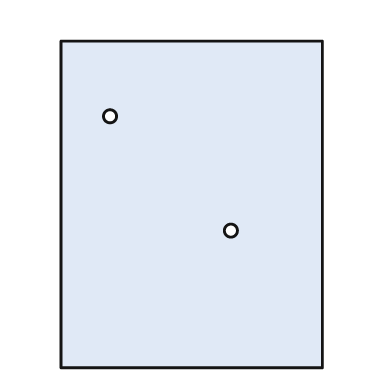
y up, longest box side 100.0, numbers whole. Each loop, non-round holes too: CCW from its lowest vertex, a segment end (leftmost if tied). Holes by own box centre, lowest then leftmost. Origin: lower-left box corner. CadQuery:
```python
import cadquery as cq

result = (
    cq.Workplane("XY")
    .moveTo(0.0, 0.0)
    .lineTo(80.0, 0.0)
    .lineTo(80.0, 100.0)
    .lineTo(0.0, 100.0)
    .close()
    .moveTo(52.0, 42.0)
    .circle(2.0)
    .moveTo(15.0, 77.0)
    .circle(2.0)
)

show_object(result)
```